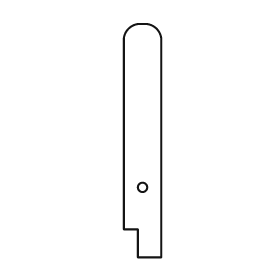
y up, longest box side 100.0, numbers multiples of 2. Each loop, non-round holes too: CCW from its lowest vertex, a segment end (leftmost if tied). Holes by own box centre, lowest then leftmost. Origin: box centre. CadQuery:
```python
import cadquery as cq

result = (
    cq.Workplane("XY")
    .moveTo(-2.0, -50.0)
    .lineTo(8.0, -50.0)
    .lineTo(8.0, 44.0)
    .threePointArc((6.0, 48.0), (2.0, 50.0))
    .lineTo(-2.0, 50.0)
    .threePointArc((-6.0, 48.0), (-8.0, 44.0))
    .lineTo(-8.0, -38.0)
    .lineTo(-2.0, -38.0)
    .close()
    .moveTo(0.0, -20.0)
    .circle(2.0)
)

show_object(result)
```